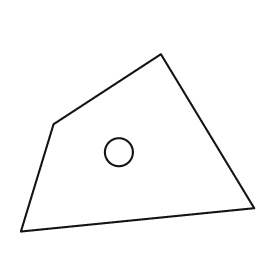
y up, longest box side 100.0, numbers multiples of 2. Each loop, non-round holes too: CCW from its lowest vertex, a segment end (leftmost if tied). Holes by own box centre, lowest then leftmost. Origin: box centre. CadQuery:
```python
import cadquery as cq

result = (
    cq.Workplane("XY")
    .moveTo(-50.0, -38.0)
    .lineTo(50.0, -28.0)
    .lineTo(10.0, 38.0)
    .lineTo(-36.0, 8.0)
    .close()
    .moveTo(-8.0, -4.0)
    .circle(6.0)
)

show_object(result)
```